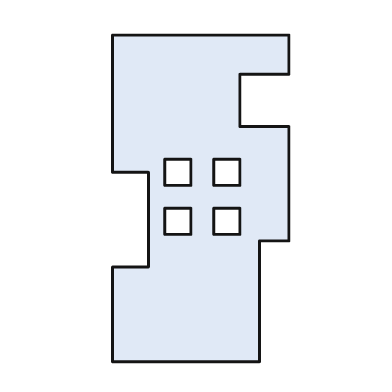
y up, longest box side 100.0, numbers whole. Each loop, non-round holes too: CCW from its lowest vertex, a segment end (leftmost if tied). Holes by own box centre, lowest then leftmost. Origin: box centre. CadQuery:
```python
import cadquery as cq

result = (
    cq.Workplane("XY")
    .moveTo(-27.0, -50.0)
    .lineTo(18.0, -50.0)
    .lineTo(18.0, -13.0)
    .lineTo(27.0, -13.0)
    .lineTo(27.0, 22.0)
    .lineTo(12.0, 22.0)
    .lineTo(12.0, 38.0)
    .lineTo(27.0, 38.0)
    .lineTo(27.0, 50.0)
    .lineTo(-27.0, 50.0)
    .lineTo(-27.0, 8.0)
    .lineTo(-16.0, 8.0)
    .lineTo(-16.0, -21.0)
    .lineTo(-27.0, -21.0)
    .close()
    .moveTo(-11.0, -11.0)
    .lineTo(-3.0, -11.0)
    .lineTo(-3.0, -3.0)
    .lineTo(-11.0, -3.0)
    .close()
    .moveTo(4.0, -11.0)
    .lineTo(12.0, -11.0)
    .lineTo(12.0, -3.0)
    .lineTo(4.0, -3.0)
    .close()
    .moveTo(-11.0, 4.0)
    .lineTo(-3.0, 4.0)
    .lineTo(-3.0, 12.0)
    .lineTo(-11.0, 12.0)
    .close()
    .moveTo(4.0, 4.0)
    .lineTo(12.0, 4.0)
    .lineTo(12.0, 12.0)
    .lineTo(4.0, 12.0)
    .close()
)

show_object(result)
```